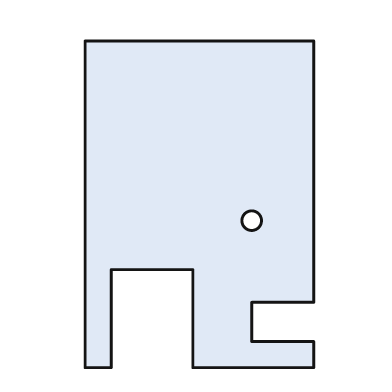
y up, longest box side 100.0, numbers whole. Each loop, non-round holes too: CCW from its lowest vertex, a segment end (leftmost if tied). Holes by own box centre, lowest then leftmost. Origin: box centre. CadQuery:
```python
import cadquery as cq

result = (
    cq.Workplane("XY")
    .moveTo(-35.0, -50.0)
    .lineTo(-27.0, -50.0)
    .lineTo(-27.0, -20.0)
    .lineTo(-2.0, -20.0)
    .lineTo(-2.0, -50.0)
    .lineTo(35.0, -50.0)
    .lineTo(35.0, -42.0)
    .lineTo(16.0, -42.0)
    .lineTo(16.0, -30.0)
    .lineTo(35.0, -30.0)
    .lineTo(35.0, 50.0)
    .lineTo(-35.0, 50.0)
    .close()
    .moveTo(16.0, -5.0)
    .circle(3.0)
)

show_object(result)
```